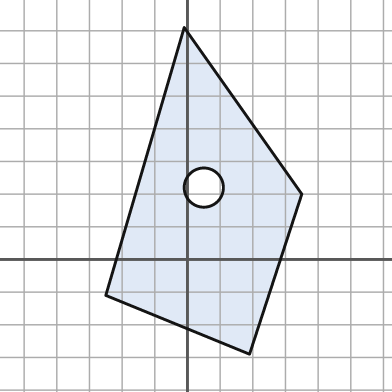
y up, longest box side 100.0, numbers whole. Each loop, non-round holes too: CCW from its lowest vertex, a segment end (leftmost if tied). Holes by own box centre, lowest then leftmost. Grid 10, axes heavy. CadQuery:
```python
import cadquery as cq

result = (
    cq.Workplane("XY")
    .moveTo(19.0, -29.0)
    .lineTo(35.0, 20.0)
    .lineTo(-1.0, 71.0)
    .lineTo(-25.0, -11.0)
    .close()
    .moveTo(5.0, 22.0)
    .circle(6.0)
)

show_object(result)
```